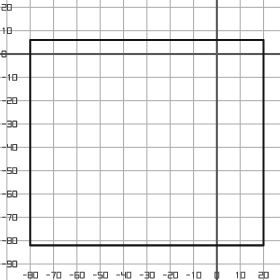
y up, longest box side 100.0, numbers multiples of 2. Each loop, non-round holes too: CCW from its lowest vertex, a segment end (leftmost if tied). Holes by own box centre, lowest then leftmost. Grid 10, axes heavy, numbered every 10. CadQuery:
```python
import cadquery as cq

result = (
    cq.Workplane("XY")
    .moveTo(-80.0, -82.0)
    .lineTo(20.0, -82.0)
    .lineTo(20.0, 6.0)
    .lineTo(-80.0, 6.0)
    .close()
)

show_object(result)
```